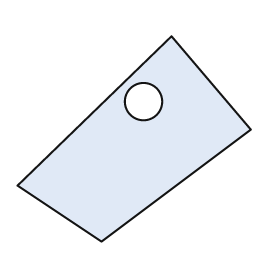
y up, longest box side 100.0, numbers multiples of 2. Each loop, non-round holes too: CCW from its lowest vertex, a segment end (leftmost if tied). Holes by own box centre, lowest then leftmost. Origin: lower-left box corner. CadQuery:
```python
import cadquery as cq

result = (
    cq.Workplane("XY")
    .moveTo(36.0, 0.0)
    .lineTo(100.0, 48.0)
    .lineTo(66.0, 88.0)
    .lineTo(0.0, 24.0)
    .close()
    .moveTo(54.0, 60.0)
    .circle(8.0)
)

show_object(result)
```